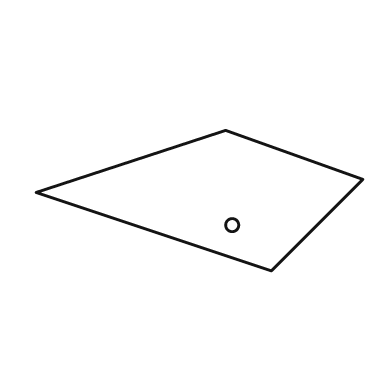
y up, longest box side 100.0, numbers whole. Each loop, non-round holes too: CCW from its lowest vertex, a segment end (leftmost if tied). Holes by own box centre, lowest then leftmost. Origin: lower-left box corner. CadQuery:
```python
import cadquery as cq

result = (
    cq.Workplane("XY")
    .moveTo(72.0, 0.0)
    .lineTo(100.0, 28.0)
    .lineTo(58.0, 43.0)
    .lineTo(0.0, 24.0)
    .close()
    .moveTo(60.0, 14.0)
    .circle(2.0)
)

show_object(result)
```